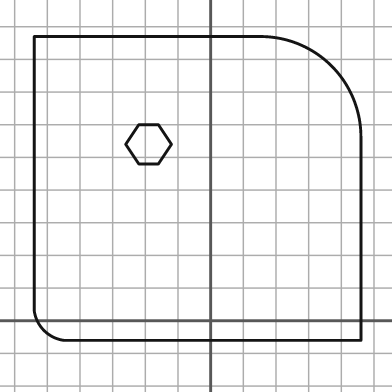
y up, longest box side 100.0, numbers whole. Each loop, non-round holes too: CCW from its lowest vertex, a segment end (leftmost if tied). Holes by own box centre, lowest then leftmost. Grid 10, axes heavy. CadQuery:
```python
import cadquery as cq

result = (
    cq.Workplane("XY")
    .moveTo(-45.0, -6.0)
    .lineTo(46.0, -6.0)
    .lineTo(46.0, 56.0)
    .threePointArc((37.0, 78.0), (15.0, 87.0))
    .lineTo(-54.0, 87.0)
    .lineTo(-54.0, 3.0)
    .threePointArc((-51.0, -3.0), (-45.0, -6.0))
    .close()
    .moveTo(-22.0, 48.0)
    .lineTo(-16.0, 48.0)
    .lineTo(-12.0, 54.0)
    .lineTo(-16.0, 60.0)
    .lineTo(-22.0, 60.0)
    .lineTo(-26.0, 54.0)
    .close()
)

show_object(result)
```